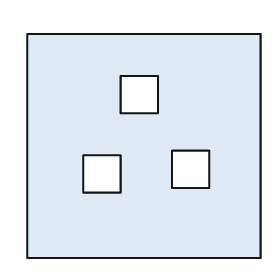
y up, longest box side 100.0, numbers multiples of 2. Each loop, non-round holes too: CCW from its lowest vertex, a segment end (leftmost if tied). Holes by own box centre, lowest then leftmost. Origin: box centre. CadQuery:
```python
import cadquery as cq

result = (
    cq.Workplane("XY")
    .moveTo(-50.0, -48.0)
    .lineTo(50.0, -48.0)
    .lineTo(50.0, 48.0)
    .lineTo(-50.0, 48.0)
    .close()
    .moveTo(-26.0, -20.0)
    .lineTo(-10.0, -20.0)
    .lineTo(-10.0, -4.0)
    .lineTo(-26.0, -4.0)
    .close()
    .moveTo(12.0, -18.0)
    .lineTo(28.0, -18.0)
    .lineTo(28.0, -2.0)
    .lineTo(12.0, -2.0)
    .close()
    .moveTo(-10.0, 14.0)
    .lineTo(6.0, 14.0)
    .lineTo(6.0, 30.0)
    .lineTo(-10.0, 30.0)
    .close()
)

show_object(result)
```